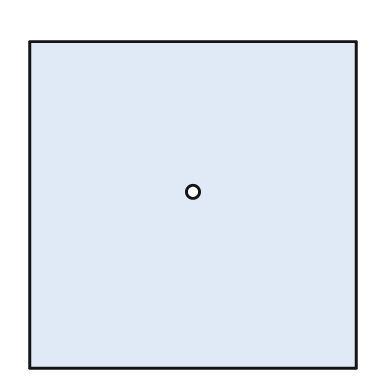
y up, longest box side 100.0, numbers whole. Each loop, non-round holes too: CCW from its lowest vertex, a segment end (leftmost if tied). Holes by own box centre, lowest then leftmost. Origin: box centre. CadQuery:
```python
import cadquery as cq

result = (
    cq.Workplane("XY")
    .moveTo(-50.0, -50.0)
    .lineTo(50.0, -50.0)
    .lineTo(50.0, 50.0)
    .lineTo(-50.0, 50.0)
    .close()
    .moveTo(0.0, 4.0)
    .circle(2.0)
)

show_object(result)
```